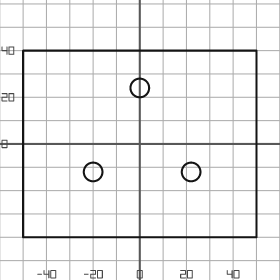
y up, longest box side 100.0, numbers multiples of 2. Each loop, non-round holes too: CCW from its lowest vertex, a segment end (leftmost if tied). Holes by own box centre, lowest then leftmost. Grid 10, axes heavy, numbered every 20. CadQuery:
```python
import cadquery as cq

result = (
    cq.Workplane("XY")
    .moveTo(-50.0, -40.0)
    .lineTo(50.0, -40.0)
    .lineTo(50.0, 40.0)
    .lineTo(-50.0, 40.0)
    .close()
    .moveTo(-20.0, -12.0)
    .circle(4.0)
    .moveTo(22.0, -12.0)
    .circle(4.0)
    .moveTo(0.0, 24.0)
    .circle(4.0)
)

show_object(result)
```